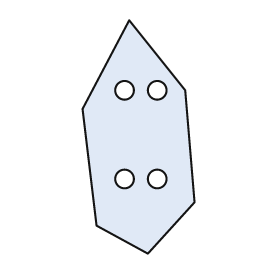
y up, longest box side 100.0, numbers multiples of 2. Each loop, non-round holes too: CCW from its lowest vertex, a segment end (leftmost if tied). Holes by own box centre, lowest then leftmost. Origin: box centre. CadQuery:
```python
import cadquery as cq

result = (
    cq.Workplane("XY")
    .moveTo(4.0, -50.0)
    .lineTo(24.0, -28.0)
    .lineTo(20.0, 20.0)
    .lineTo(-4.0, 50.0)
    .lineTo(-24.0, 12.0)
    .lineTo(-18.0, -38.0)
    .close()
    .moveTo(-6.0, -18.0)
    .circle(4.0)
    .moveTo(8.0, -18.0)
    .circle(4.0)
    .moveTo(-6.0, 20.0)
    .circle(4.0)
    .moveTo(8.0, 20.0)
    .circle(4.0)
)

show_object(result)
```